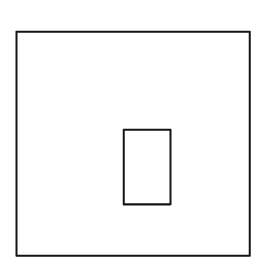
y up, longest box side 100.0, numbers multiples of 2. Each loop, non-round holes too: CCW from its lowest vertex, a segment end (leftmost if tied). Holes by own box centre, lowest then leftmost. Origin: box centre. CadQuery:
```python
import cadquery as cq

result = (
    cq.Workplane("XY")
    .moveTo(-50.0, -48.0)
    .lineTo(50.0, -48.0)
    .lineTo(50.0, 48.0)
    .lineTo(-50.0, 48.0)
    .close()
    .moveTo(-4.0, -26.0)
    .lineTo(16.0, -26.0)
    .lineTo(16.0, 6.0)
    .lineTo(-4.0, 6.0)
    .close()
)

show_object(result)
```